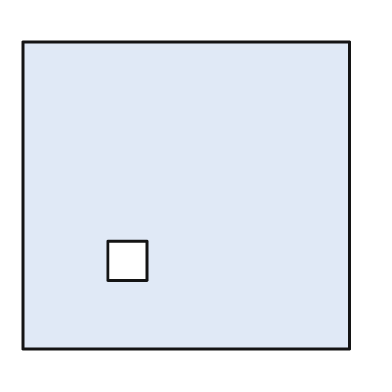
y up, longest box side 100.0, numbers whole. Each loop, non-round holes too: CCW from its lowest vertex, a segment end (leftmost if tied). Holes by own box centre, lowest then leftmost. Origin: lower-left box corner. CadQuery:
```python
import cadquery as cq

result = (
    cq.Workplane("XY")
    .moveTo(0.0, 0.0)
    .lineTo(100.0, 0.0)
    .lineTo(100.0, 94.0)
    .lineTo(0.0, 94.0)
    .close()
    .moveTo(26.0, 21.0)
    .lineTo(38.0, 21.0)
    .lineTo(38.0, 33.0)
    .lineTo(26.0, 33.0)
    .close()
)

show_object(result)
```